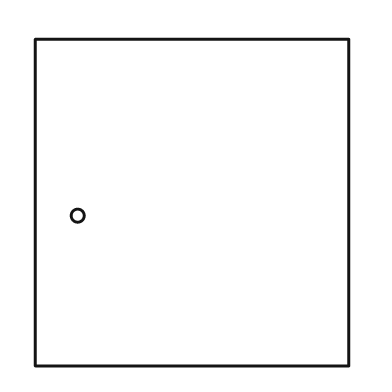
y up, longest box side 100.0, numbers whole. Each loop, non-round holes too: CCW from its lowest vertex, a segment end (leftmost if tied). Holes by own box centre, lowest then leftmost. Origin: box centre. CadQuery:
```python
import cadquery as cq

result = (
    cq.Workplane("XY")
    .moveTo(-48.0, -50.0)
    .lineTo(48.0, -50.0)
    .lineTo(48.0, 50.0)
    .lineTo(-48.0, 50.0)
    .close()
    .moveTo(-35.0, -4.0)
    .circle(2.0)
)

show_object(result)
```